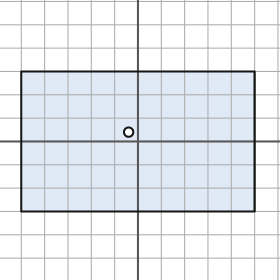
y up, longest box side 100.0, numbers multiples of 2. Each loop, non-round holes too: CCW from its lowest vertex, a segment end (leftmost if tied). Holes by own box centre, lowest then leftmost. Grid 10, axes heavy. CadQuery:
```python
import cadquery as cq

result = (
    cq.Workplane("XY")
    .moveTo(-50.0, -30.0)
    .lineTo(50.0, -30.0)
    .lineTo(50.0, 30.0)
    .lineTo(-50.0, 30.0)
    .close()
    .moveTo(-4.0, 4.0)
    .circle(2.0)
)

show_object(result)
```